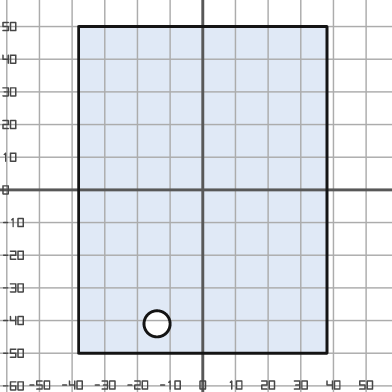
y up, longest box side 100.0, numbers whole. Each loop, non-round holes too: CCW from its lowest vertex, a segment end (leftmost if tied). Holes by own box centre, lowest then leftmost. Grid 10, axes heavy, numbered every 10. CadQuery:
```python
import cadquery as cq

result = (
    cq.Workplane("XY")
    .moveTo(-38.0, -50.0)
    .lineTo(38.0, -50.0)
    .lineTo(38.0, 50.0)
    .lineTo(-38.0, 50.0)
    .close()
    .moveTo(-14.0, -41.0)
    .circle(4.0)
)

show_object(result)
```